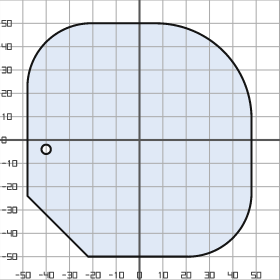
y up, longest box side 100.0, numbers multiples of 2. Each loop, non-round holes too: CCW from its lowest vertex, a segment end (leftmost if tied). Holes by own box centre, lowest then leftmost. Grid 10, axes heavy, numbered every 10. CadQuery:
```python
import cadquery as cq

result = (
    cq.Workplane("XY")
    .moveTo(-22.0, -50.0)
    .lineTo(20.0, -50.0)
    .threePointArc((40.0, -42.0), (48.0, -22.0))
    .lineTo(48.0, 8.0)
    .threePointArc((36.0, 38.0), (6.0, 50.0))
    .lineTo(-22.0, 50.0)
    .threePointArc((-40.0, 42.0), (-48.0, 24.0))
    .lineTo(-48.0, -24.0)
    .close()
    .moveTo(-40.0, -4.0)
    .circle(2.0)
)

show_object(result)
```